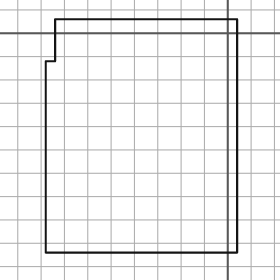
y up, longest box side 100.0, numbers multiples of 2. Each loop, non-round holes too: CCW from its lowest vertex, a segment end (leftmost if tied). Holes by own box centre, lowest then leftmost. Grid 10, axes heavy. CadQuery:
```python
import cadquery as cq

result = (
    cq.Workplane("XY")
    .moveTo(-78.0, -94.0)
    .lineTo(4.0, -94.0)
    .lineTo(4.0, 6.0)
    .lineTo(-74.0, 6.0)
    .lineTo(-74.0, -12.0)
    .lineTo(-78.0, -12.0)
    .close()
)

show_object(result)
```